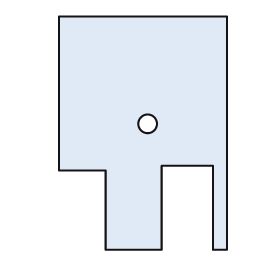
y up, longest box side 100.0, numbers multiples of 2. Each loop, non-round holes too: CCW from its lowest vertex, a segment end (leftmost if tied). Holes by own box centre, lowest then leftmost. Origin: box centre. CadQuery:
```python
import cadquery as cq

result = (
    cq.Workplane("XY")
    .moveTo(-16.0, -50.0)
    .lineTo(8.0, -50.0)
    .lineTo(8.0, -14.0)
    .lineTo(30.0, -14.0)
    .lineTo(30.0, -50.0)
    .lineTo(36.0, -50.0)
    .lineTo(36.0, 50.0)
    .lineTo(-36.0, 50.0)
    .lineTo(-36.0, -16.0)
    .lineTo(-16.0, -16.0)
    .close()
    .moveTo(2.0, 4.0)
    .circle(4.0)
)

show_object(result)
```